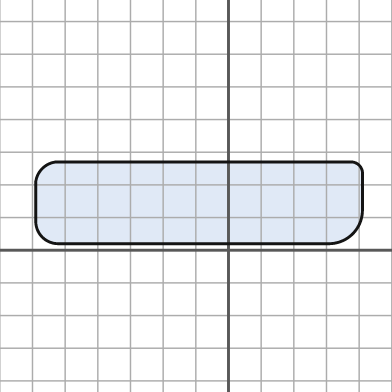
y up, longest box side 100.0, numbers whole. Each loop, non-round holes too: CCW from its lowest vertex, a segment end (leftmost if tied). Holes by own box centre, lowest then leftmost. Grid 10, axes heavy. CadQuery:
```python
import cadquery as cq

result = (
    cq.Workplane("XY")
    .moveTo(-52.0, 2.0)
    .lineTo(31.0, 2.0)
    .threePointArc((38.0, 5.0), (41.0, 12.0))
    .lineTo(41.0, 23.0)
    .threePointArc((40.0, 26.0), (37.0, 27.0))
    .lineTo(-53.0, 27.0)
    .threePointArc((-57.0, 25.0), (-59.0, 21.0))
    .lineTo(-59.0, 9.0)
    .threePointArc((-57.0, 4.0), (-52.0, 2.0))
    .close()
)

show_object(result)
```